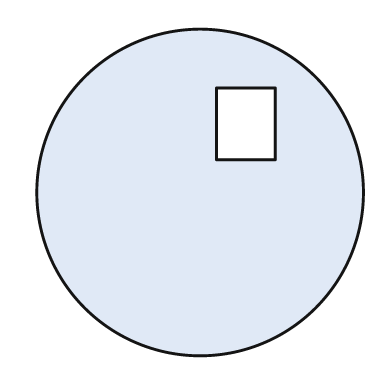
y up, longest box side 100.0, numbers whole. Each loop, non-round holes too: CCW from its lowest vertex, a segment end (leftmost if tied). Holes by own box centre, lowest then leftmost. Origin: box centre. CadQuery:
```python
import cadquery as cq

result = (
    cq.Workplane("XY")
    .moveTo(0.0, 0.0)
    .circle(50.0)
    .moveTo(5.0, 10.0)
    .lineTo(23.0, 10.0)
    .lineTo(23.0, 32.0)
    .lineTo(5.0, 32.0)
    .close()
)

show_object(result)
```